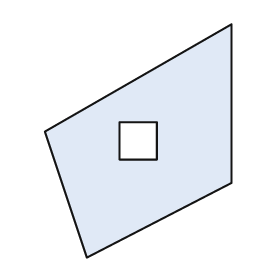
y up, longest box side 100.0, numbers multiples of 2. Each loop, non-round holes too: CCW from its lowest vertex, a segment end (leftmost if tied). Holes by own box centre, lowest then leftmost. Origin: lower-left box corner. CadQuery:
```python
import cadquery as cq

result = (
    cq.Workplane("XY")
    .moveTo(18.0, 0.0)
    .lineTo(80.0, 32.0)
    .lineTo(80.0, 100.0)
    .lineTo(0.0, 54.0)
    .close()
    .moveTo(32.0, 42.0)
    .lineTo(48.0, 42.0)
    .lineTo(48.0, 58.0)
    .lineTo(32.0, 58.0)
    .close()
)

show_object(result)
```